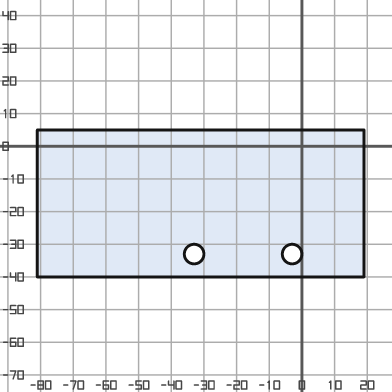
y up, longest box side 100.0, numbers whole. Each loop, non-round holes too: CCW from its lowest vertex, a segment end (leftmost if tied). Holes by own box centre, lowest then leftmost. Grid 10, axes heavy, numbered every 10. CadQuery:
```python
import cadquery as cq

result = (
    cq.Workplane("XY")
    .moveTo(-81.0, -40.0)
    .lineTo(19.0, -40.0)
    .lineTo(19.0, 5.0)
    .lineTo(-81.0, 5.0)
    .close()
    .moveTo(-33.0, -33.0)
    .circle(3.0)
    .moveTo(-3.0, -33.0)
    .circle(3.0)
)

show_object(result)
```